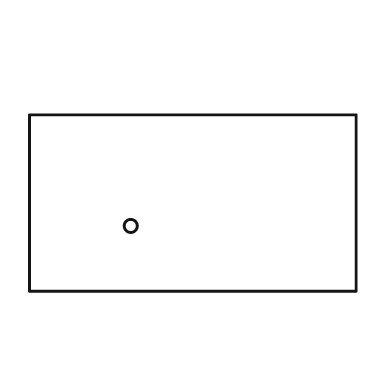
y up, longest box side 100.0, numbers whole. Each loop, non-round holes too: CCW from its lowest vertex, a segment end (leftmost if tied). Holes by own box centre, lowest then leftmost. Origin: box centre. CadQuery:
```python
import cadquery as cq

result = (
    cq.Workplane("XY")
    .moveTo(-50.0, -27.0)
    .lineTo(50.0, -27.0)
    .lineTo(50.0, 27.0)
    .lineTo(-50.0, 27.0)
    .close()
    .moveTo(-19.0, -7.0)
    .circle(2.0)
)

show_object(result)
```